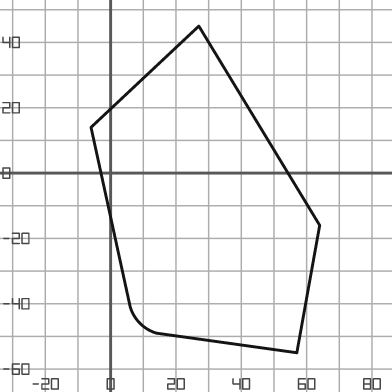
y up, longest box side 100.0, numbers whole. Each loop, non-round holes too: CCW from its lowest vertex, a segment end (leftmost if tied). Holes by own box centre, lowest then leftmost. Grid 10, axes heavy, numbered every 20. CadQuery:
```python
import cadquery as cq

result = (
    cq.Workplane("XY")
    .moveTo(57.0, -55.0)
    .lineTo(64.0, -16.0)
    .lineTo(27.0, 45.0)
    .lineTo(-6.0, 14.0)
    .lineTo(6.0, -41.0)
    .threePointArc((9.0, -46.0), (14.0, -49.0))
    .close()
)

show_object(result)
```